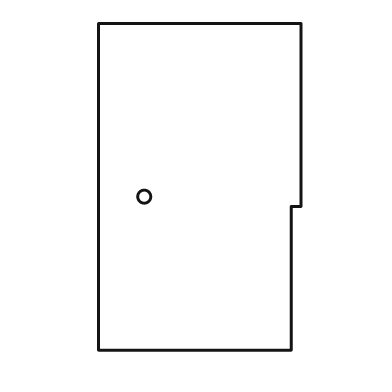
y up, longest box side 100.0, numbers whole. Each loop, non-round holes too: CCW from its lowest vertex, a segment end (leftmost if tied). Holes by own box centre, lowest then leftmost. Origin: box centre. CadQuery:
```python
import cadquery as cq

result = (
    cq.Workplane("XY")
    .moveTo(-31.0, -50.0)
    .lineTo(28.0, -50.0)
    .lineTo(28.0, -6.0)
    .lineTo(31.0, -6.0)
    .lineTo(31.0, 50.0)
    .lineTo(-31.0, 50.0)
    .close()
    .moveTo(-17.0, -3.0)
    .circle(2.0)
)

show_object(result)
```